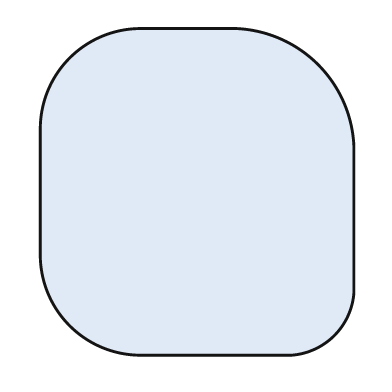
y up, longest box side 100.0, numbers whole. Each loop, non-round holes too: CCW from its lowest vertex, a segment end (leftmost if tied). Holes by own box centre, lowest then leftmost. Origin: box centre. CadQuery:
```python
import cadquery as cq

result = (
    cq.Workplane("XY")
    .moveTo(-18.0, -50.0)
    .lineTo(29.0, -50.0)
    .threePointArc((42.0, -44.0), (48.0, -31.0))
    .lineTo(48.0, 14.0)
    .threePointArc((37.0, 39.0), (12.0, 50.0))
    .lineTo(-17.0, 50.0)
    .threePointArc((-39.0, 41.0), (-48.0, 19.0))
    .lineTo(-48.0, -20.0)
    .threePointArc((-39.0, -41.0), (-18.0, -50.0))
    .close()
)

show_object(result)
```